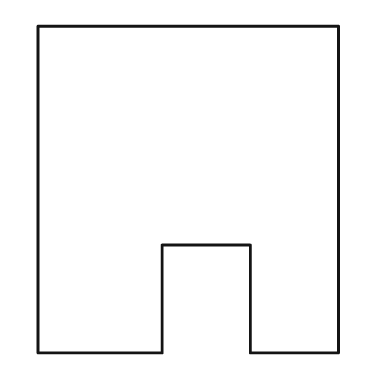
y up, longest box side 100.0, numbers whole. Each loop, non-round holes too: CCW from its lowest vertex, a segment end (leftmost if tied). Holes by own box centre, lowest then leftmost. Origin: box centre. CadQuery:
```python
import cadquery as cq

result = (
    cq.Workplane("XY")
    .moveTo(-46.0, -50.0)
    .lineTo(-8.0, -50.0)
    .lineTo(-8.0, -17.0)
    .lineTo(19.0, -17.0)
    .lineTo(19.0, -50.0)
    .lineTo(46.0, -50.0)
    .lineTo(46.0, 50.0)
    .lineTo(-46.0, 50.0)
    .close()
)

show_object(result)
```